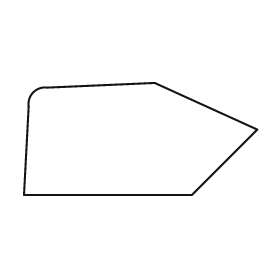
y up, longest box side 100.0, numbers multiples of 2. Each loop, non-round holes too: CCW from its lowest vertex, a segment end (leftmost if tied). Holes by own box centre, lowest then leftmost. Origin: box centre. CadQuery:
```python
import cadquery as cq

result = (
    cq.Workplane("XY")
    .moveTo(-50.0, -24.0)
    .lineTo(22.0, -24.0)
    .lineTo(50.0, 4.0)
    .lineTo(6.0, 24.0)
    .lineTo(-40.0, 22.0)
    .threePointArc((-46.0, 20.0), (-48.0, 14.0))
    .close()
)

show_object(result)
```